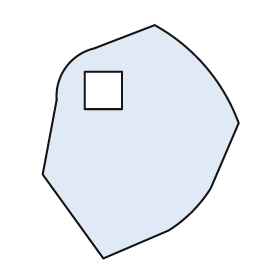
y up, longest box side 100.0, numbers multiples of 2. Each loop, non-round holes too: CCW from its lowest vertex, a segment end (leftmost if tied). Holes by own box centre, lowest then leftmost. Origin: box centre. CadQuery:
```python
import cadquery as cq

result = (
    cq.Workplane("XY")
    .moveTo(-16.0, -50.0)
    .lineTo(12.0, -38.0)
    .threePointArc((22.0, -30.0), (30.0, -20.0))
    .lineTo(42.0, 8.0)
    .threePointArc((28.0, 32.0), (6.0, 50.0))
    .lineTo(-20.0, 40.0)
    .threePointArc((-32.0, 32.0), (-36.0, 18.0))
    .lineTo(-42.0, -14.0)
    .close()
    .moveTo(-24.0, 14.0)
    .lineTo(-8.0, 14.0)
    .lineTo(-8.0, 30.0)
    .lineTo(-24.0, 30.0)
    .close()
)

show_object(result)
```